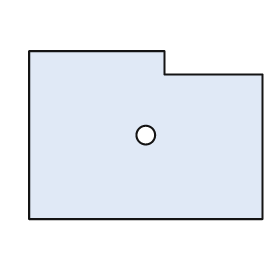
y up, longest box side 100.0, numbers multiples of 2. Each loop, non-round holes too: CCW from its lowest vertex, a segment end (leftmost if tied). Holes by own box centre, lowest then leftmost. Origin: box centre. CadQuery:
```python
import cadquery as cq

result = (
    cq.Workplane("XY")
    .moveTo(-50.0, -36.0)
    .lineTo(50.0, -36.0)
    .lineTo(50.0, 26.0)
    .lineTo(8.0, 26.0)
    .lineTo(8.0, 36.0)
    .lineTo(-50.0, 36.0)
    .close()
    .moveTo(0.0, 0.0)
    .circle(4.0)
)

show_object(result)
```